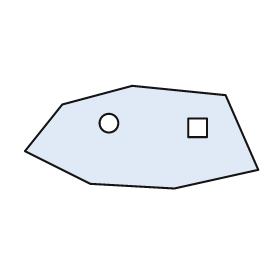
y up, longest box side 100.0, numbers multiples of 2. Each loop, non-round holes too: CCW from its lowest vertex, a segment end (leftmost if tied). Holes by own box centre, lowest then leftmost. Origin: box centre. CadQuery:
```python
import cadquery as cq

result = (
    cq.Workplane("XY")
    .moveTo(14.0, -22.0)
    .lineTo(50.0, -14.0)
    .lineTo(36.0, 18.0)
    .lineTo(-4.0, 22.0)
    .lineTo(-34.0, 14.0)
    .lineTo(-50.0, -6.0)
    .lineTo(-22.0, -20.0)
    .close()
    .moveTo(20.0, 0.0)
    .lineTo(28.0, 0.0)
    .lineTo(28.0, 8.0)
    .lineTo(20.0, 8.0)
    .close()
    .moveTo(-14.0, 6.0)
    .circle(4.0)
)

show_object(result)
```